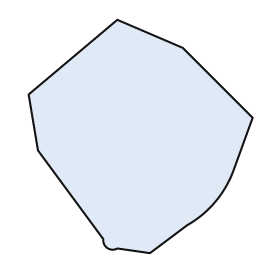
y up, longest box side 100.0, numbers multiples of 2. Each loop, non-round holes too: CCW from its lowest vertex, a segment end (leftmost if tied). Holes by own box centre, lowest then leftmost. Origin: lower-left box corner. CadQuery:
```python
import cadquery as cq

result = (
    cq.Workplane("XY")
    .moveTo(52.0, 0.0)
    .lineTo(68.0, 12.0)
    .threePointArc((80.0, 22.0), (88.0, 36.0))
    .lineTo(96.0, 58.0)
    .lineTo(66.0, 88.0)
    .lineTo(38.0, 100.0)
    .lineTo(0.0, 68.0)
    .lineTo(4.0, 44.0)
    .lineTo(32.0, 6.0)
    .threePointArc((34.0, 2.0), (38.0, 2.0))
    .close()
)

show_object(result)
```